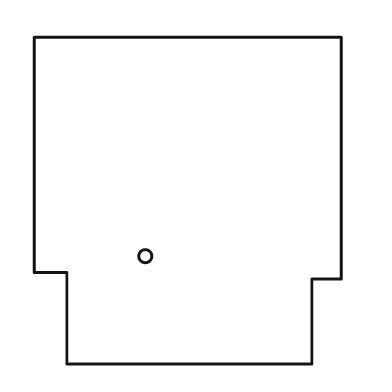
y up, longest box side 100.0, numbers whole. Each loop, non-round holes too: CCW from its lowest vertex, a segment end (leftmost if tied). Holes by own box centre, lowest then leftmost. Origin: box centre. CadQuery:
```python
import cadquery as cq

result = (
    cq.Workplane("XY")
    .moveTo(-37.0, -50.0)
    .lineTo(38.0, -50.0)
    .lineTo(38.0, -24.0)
    .lineTo(47.0, -24.0)
    .lineTo(47.0, 50.0)
    .lineTo(-47.0, 50.0)
    .lineTo(-47.0, -22.0)
    .lineTo(-37.0, -22.0)
    .close()
    .moveTo(-13.0, -17.0)
    .circle(2.0)
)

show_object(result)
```